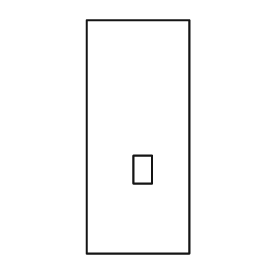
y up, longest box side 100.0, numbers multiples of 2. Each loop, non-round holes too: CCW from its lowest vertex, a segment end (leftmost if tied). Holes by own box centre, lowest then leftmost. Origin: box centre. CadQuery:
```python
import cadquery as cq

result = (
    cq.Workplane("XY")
    .moveTo(-22.0, -50.0)
    .lineTo(22.0, -50.0)
    .lineTo(22.0, 50.0)
    .lineTo(-22.0, 50.0)
    .close()
    .moveTo(-2.0, -20.0)
    .lineTo(6.0, -20.0)
    .lineTo(6.0, -8.0)
    .lineTo(-2.0, -8.0)
    .close()
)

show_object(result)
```